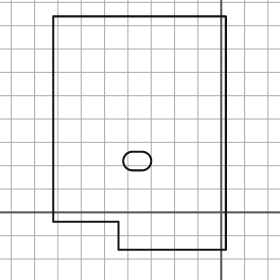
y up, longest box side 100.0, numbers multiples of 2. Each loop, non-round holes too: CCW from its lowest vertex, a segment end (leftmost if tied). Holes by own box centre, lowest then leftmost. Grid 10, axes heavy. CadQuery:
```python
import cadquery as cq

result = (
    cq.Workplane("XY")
    .moveTo(-44.0, -16.0)
    .lineTo(2.0, -16.0)
    .lineTo(2.0, 84.0)
    .lineTo(-72.0, 84.0)
    .lineTo(-72.0, -4.0)
    .lineTo(-44.0, -4.0)
    .close()
    .moveTo(-38.0, 18.0)
    .lineTo(-34.0, 18.0)
    .threePointArc((-30.0, 22.0), (-34.0, 26.0))
    .lineTo(-38.0, 26.0)
    .threePointArc((-42.0, 22.0), (-38.0, 18.0))
    .close()
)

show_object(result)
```